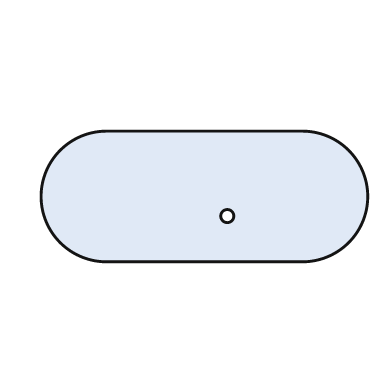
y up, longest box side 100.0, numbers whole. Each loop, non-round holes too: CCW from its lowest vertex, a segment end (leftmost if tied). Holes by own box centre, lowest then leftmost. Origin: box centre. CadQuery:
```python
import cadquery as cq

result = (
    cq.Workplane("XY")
    .moveTo(-30.0, -20.0)
    .lineTo(30.0, -20.0)
    .threePointArc((50.0, 0.0), (30.0, 20.0))
    .lineTo(-30.0, 20.0)
    .threePointArc((-50.0, 0.0), (-30.0, -20.0))
    .close()
    .moveTo(7.0, -6.0)
    .circle(2.0)
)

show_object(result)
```